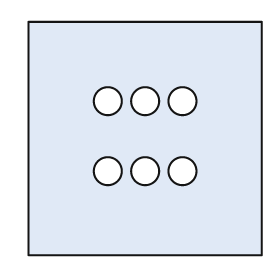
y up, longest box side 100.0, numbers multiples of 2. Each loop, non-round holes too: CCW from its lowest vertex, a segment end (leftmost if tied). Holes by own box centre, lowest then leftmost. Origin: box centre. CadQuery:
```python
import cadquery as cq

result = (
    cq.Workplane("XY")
    .moveTo(-50.0, -50.0)
    .lineTo(50.0, -50.0)
    .lineTo(50.0, 50.0)
    .lineTo(-50.0, 50.0)
    .close()
    .moveTo(-16.0, -14.0)
    .circle(6.0)
    .moveTo(0.0, -14.0)
    .circle(6.0)
    .moveTo(16.0, -14.0)
    .circle(6.0)
    .moveTo(-16.0, 16.0)
    .circle(6.0)
    .moveTo(0.0, 16.0)
    .circle(6.0)
    .moveTo(16.0, 16.0)
    .circle(6.0)
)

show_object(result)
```